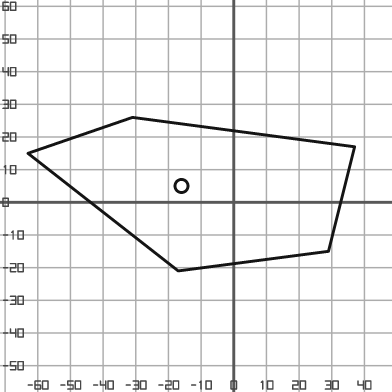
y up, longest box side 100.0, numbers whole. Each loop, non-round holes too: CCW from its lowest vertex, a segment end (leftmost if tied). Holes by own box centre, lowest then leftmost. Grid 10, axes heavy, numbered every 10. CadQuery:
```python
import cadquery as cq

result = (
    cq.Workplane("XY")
    .moveTo(-17.0, -21.0)
    .lineTo(29.0, -15.0)
    .lineTo(37.0, 17.0)
    .lineTo(-31.0, 26.0)
    .lineTo(-63.0, 15.0)
    .close()
    .moveTo(-16.0, 5.0)
    .circle(2.0)
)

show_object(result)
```